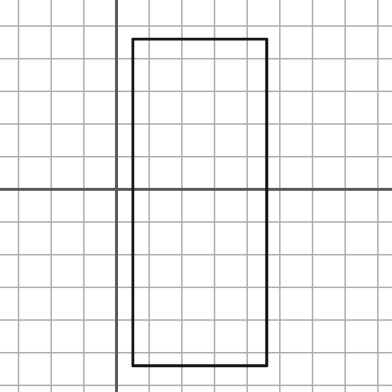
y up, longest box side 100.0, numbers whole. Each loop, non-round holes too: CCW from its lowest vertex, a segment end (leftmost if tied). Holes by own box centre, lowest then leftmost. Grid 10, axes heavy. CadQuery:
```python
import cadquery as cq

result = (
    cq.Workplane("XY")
    .moveTo(5.0, -54.0)
    .lineTo(46.0, -54.0)
    .lineTo(46.0, 46.0)
    .lineTo(5.0, 46.0)
    .close()
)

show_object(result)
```